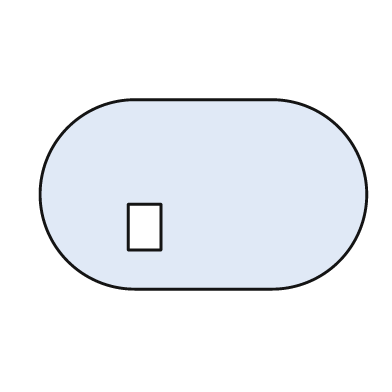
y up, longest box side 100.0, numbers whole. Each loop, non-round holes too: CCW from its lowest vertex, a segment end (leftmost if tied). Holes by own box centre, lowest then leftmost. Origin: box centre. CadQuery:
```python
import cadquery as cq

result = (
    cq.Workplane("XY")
    .moveTo(-21.0, -29.0)
    .lineTo(21.0, -29.0)
    .threePointArc((50.0, 0.0), (21.0, 29.0))
    .lineTo(-21.0, 29.0)
    .threePointArc((-50.0, 0.0), (-21.0, -29.0))
    .close()
    .moveTo(-23.0, -17.0)
    .lineTo(-13.0, -17.0)
    .lineTo(-13.0, -3.0)
    .lineTo(-23.0, -3.0)
    .close()
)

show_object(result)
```